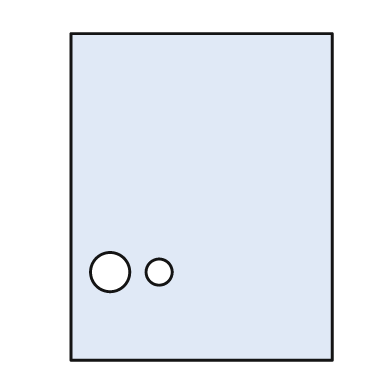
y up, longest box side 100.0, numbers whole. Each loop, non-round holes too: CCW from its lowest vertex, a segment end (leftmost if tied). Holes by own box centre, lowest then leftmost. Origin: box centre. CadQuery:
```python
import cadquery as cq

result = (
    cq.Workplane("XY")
    .moveTo(-40.0, -50.0)
    .lineTo(40.0, -50.0)
    .lineTo(40.0, 50.0)
    .lineTo(-40.0, 50.0)
    .close()
    .moveTo(-28.0, -23.0)
    .circle(6.0)
    .moveTo(-13.0, -23.0)
    .circle(4.0)
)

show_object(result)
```